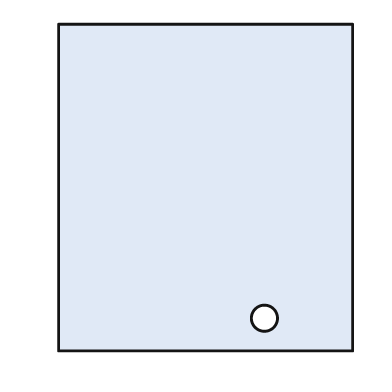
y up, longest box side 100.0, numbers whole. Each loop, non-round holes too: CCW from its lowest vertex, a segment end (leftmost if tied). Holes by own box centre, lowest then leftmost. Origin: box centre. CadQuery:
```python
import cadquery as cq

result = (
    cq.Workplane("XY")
    .moveTo(-45.0, -50.0)
    .lineTo(45.0, -50.0)
    .lineTo(45.0, 50.0)
    .lineTo(-45.0, 50.0)
    .close()
    .moveTo(18.0, -40.0)
    .circle(4.0)
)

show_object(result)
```